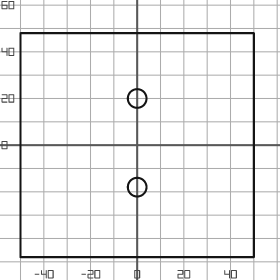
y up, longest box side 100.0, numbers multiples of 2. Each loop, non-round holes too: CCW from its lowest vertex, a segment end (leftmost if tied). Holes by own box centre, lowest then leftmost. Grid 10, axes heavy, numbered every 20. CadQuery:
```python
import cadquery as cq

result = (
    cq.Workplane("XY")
    .moveTo(-50.0, -48.0)
    .lineTo(50.0, -48.0)
    .lineTo(50.0, 48.0)
    .lineTo(-50.0, 48.0)
    .close()
    .moveTo(0.0, -18.0)
    .circle(4.0)
    .moveTo(0.0, 20.0)
    .circle(4.0)
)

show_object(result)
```